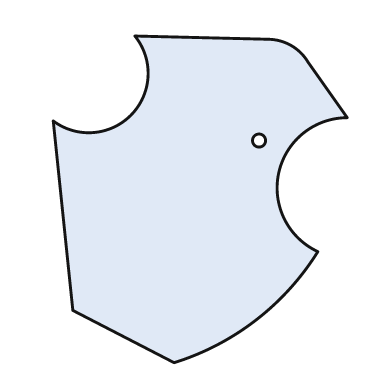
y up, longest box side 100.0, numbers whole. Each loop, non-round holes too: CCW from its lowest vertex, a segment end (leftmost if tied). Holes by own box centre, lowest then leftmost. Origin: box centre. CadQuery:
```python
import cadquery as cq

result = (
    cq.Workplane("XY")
    .moveTo(-8.0, -50.0)
    .threePointArc((17.0, -37.0), (36.0, -16.0))
    .threePointArc((24.0, 8.0), (45.0, 25.0))
    .lineTo(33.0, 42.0)
    .threePointArc((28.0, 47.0), (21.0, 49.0))
    .lineTo(-20.0, 50.0)
    .threePointArc((-21.0, 26.0), (-45.0, 24.0))
    .lineTo(-39.0, -34.0)
    .close()
    .moveTo(18.0, 18.0)
    .circle(2.0)
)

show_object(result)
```